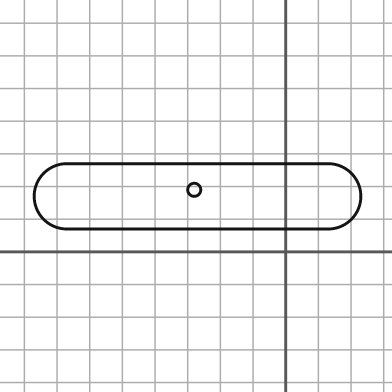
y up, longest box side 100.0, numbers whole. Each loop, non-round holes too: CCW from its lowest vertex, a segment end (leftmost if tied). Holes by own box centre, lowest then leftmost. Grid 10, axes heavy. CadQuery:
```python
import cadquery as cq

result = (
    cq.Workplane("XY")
    .moveTo(-67.0, 7.0)
    .lineTo(13.0, 7.0)
    .threePointArc((23.0, 17.0), (13.0, 27.0))
    .lineTo(-67.0, 27.0)
    .threePointArc((-77.0, 17.0), (-67.0, 7.0))
    .close()
    .moveTo(-28.0, 19.0)
    .circle(2.0)
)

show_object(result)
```